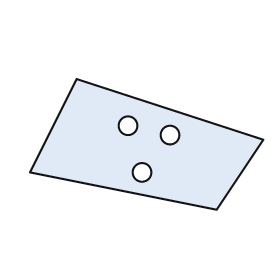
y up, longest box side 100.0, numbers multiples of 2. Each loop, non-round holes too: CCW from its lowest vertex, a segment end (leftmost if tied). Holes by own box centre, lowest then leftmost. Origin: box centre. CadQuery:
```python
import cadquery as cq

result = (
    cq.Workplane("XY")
    .moveTo(30.0, -28.0)
    .lineTo(50.0, 2.0)
    .lineTo(-30.0, 28.0)
    .lineTo(-50.0, -12.0)
    .close()
    .moveTo(-2.0, -12.0)
    .circle(4.0)
    .moveTo(10.0, 4.0)
    .circle(4.0)
    .moveTo(-8.0, 8.0)
    .circle(4.0)
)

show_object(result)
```